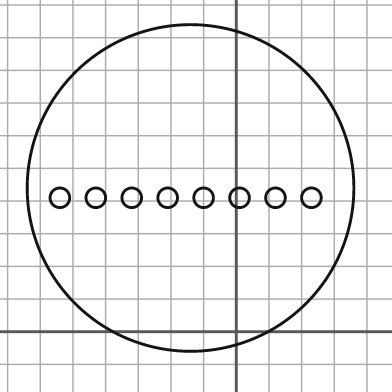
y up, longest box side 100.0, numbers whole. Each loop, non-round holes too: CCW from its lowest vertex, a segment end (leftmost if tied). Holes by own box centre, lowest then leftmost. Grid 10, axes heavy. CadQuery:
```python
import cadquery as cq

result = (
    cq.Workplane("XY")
    .moveTo(-14.0, 44.0)
    .circle(50.0)
    .moveTo(-54.0, 41.0)
    .circle(3.0)
    .moveTo(-43.0, 41.0)
    .circle(3.0)
    .moveTo(-32.0, 41.0)
    .circle(3.0)
    .moveTo(-21.0, 41.0)
    .circle(3.0)
    .moveTo(-10.0, 41.0)
    .circle(3.0)
    .moveTo(1.0, 41.0)
    .circle(3.0)
    .moveTo(12.0, 41.0)
    .circle(3.0)
    .moveTo(23.0, 41.0)
    .circle(3.0)
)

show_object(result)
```